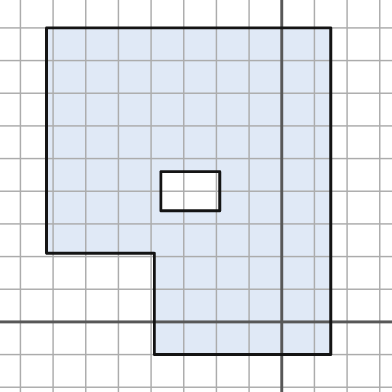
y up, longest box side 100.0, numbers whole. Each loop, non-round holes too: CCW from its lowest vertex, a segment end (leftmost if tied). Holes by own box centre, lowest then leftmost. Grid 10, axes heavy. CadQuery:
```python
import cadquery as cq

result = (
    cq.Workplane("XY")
    .moveTo(-39.0, -10.0)
    .lineTo(15.0, -10.0)
    .lineTo(15.0, 90.0)
    .lineTo(-72.0, 90.0)
    .lineTo(-72.0, 21.0)
    .lineTo(-39.0, 21.0)
    .close()
    .moveTo(-37.0, 34.0)
    .lineTo(-19.0, 34.0)
    .lineTo(-19.0, 46.0)
    .lineTo(-37.0, 46.0)
    .close()
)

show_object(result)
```